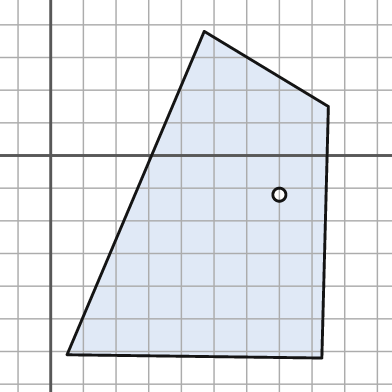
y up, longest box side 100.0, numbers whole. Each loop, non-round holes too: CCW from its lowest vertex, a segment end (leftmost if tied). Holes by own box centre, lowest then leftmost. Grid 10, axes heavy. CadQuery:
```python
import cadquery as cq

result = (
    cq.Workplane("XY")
    .moveTo(83.0, -62.0)
    .lineTo(85.0, 15.0)
    .lineTo(47.0, 38.0)
    .lineTo(5.0, -61.0)
    .close()
    .moveTo(70.0, -12.0)
    .circle(2.0)
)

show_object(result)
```